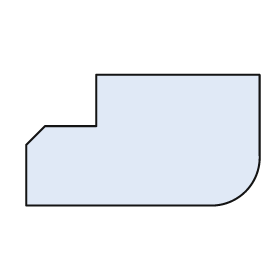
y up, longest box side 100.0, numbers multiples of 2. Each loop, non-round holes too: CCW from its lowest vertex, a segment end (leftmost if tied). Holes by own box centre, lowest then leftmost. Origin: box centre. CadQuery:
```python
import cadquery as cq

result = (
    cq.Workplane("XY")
    .moveTo(-50.0, -28.0)
    .lineTo(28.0, -28.0)
    .threePointArc((44.0, -22.0), (50.0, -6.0))
    .lineTo(50.0, 28.0)
    .lineTo(-20.0, 28.0)
    .lineTo(-20.0, 6.0)
    .lineTo(-42.0, 6.0)
    .lineTo(-50.0, -2.0)
    .close()
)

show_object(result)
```